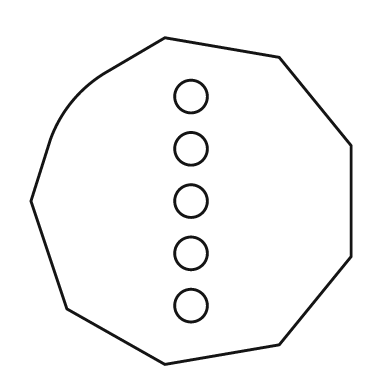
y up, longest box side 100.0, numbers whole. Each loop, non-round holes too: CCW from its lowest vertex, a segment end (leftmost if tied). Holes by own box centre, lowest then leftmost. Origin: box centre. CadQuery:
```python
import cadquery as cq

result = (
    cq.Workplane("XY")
    .moveTo(-8.0, -50.0)
    .lineTo(27.0, -44.0)
    .lineTo(49.0, -17.0)
    .lineTo(49.0, 17.0)
    .lineTo(27.0, 44.0)
    .lineTo(-8.0, 50.0)
    .lineTo(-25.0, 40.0)
    .threePointArc((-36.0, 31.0), (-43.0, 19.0))
    .lineTo(-49.0, 0.0)
    .lineTo(-38.0, -33.0)
    .close()
    .moveTo(0.0, -32.0)
    .circle(5.0)
    .moveTo(0.0, -16.0)
    .circle(5.0)
    .moveTo(0.0, 0.0)
    .circle(5.0)
    .moveTo(0.0, 16.0)
    .circle(5.0)
    .moveTo(0.0, 32.0)
    .circle(5.0)
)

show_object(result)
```